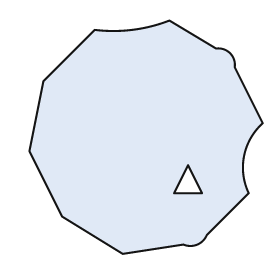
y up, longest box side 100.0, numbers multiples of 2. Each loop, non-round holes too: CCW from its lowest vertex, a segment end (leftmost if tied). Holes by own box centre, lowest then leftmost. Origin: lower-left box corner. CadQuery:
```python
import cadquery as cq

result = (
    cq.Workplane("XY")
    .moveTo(40.0, 0.0)
    .lineTo(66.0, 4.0)
    .threePointArc((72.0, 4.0), (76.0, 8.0))
    .lineTo(94.0, 26.0)
    .threePointArc((92.0, 42.0), (100.0, 56.0))
    .lineTo(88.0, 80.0)
    .threePointArc((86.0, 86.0), (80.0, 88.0))
    .lineTo(60.0, 100.0)
    .threePointArc((44.0, 96.0), (28.0, 96.0))
    .lineTo(6.0, 74.0)
    .lineTo(0.0, 44.0)
    .lineTo(14.0, 16.0)
    .close()
    .moveTo(62.0, 26.0)
    .lineTo(74.0, 26.0)
    .lineTo(68.0, 38.0)
    .close()
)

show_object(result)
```